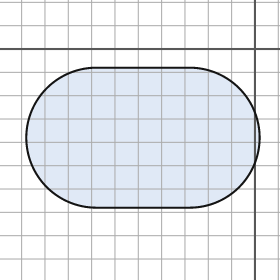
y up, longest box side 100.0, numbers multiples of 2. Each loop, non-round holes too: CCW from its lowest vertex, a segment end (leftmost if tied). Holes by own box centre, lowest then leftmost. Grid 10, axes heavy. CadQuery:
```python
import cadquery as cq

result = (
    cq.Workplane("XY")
    .moveTo(-68.0, -68.0)
    .lineTo(-28.0, -68.0)
    .threePointArc((2.0, -38.0), (-28.0, -8.0))
    .lineTo(-68.0, -8.0)
    .threePointArc((-98.0, -38.0), (-68.0, -68.0))
    .close()
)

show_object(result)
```